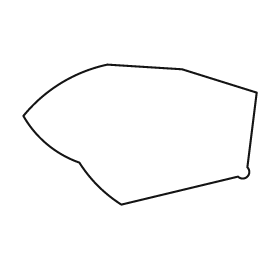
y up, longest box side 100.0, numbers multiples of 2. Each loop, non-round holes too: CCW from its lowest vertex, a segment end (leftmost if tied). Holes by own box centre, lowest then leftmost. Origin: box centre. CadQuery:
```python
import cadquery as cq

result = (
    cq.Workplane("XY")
    .moveTo(-8.0, -30.0)
    .lineTo(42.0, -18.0)
    .threePointArc((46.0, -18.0), (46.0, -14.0))
    .lineTo(50.0, 18.0)
    .lineTo(18.0, 28.0)
    .lineTo(-14.0, 30.0)
    .threePointArc((-34.0, 22.0), (-50.0, 8.0))
    .threePointArc((-40.0, -4.0), (-26.0, -12.0))
    .threePointArc((-18.0, -22.0), (-8.0, -30.0))
    .close()
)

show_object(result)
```